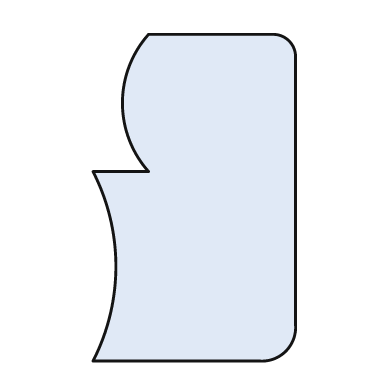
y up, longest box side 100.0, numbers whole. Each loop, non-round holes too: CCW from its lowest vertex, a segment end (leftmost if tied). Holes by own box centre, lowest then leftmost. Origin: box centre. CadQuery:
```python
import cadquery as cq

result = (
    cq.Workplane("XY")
    .moveTo(-31.0, -50.0)
    .lineTo(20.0, -50.0)
    .threePointArc((28.0, -47.0), (31.0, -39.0))
    .lineTo(31.0, 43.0)
    .threePointArc((29.0, 48.0), (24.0, 50.0))
    .lineTo(-14.0, 50.0)
    .threePointArc((-22.0, 29.0), (-14.0, 8.0))
    .lineTo(-31.0, 8.0)
    .threePointArc((-24.0, -21.0), (-31.0, -50.0))
    .close()
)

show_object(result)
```